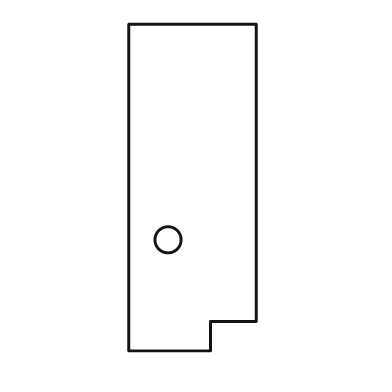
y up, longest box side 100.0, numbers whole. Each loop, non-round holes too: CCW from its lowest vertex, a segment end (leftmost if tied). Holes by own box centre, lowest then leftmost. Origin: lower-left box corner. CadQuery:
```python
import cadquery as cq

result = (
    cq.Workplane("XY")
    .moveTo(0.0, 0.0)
    .lineTo(25.0, 0.0)
    .lineTo(25.0, 9.0)
    .lineTo(39.0, 9.0)
    .lineTo(39.0, 100.0)
    .lineTo(0.0, 100.0)
    .close()
    .moveTo(12.0, 34.0)
    .circle(4.0)
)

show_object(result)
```